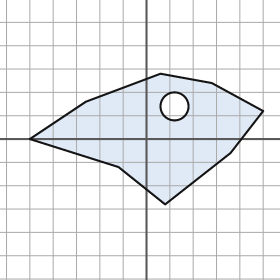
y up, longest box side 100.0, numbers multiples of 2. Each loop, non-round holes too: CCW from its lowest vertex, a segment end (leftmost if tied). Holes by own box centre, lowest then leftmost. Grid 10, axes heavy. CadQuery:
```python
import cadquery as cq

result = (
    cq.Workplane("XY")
    .moveTo(8.0, -28.0)
    .lineTo(36.0, -6.0)
    .lineTo(50.0, 12.0)
    .lineTo(28.0, 24.0)
    .lineTo(6.0, 28.0)
    .lineTo(-26.0, 16.0)
    .lineTo(-50.0, 0.0)
    .lineTo(-12.0, -12.0)
    .close()
    .moveTo(12.0, 14.0)
    .circle(6.0)
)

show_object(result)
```